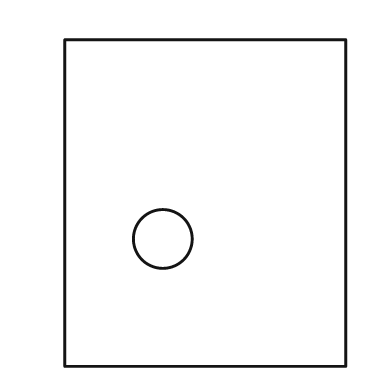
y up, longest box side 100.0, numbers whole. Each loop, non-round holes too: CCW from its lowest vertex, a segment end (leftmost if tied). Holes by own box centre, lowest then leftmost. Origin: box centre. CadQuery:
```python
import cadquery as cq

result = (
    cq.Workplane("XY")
    .moveTo(-43.0, -50.0)
    .lineTo(43.0, -50.0)
    .lineTo(43.0, 50.0)
    .lineTo(-43.0, 50.0)
    .close()
    .moveTo(-13.0, -11.0)
    .circle(9.0)
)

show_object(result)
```